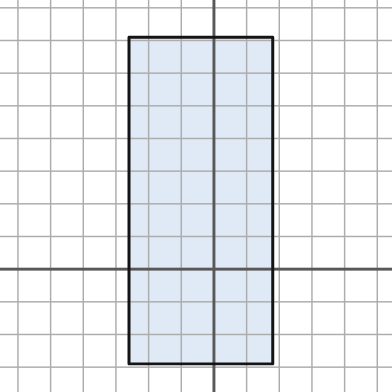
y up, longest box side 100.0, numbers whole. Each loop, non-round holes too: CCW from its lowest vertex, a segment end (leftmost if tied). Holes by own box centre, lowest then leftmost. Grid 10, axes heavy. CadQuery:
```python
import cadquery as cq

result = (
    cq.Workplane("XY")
    .moveTo(-26.0, -29.0)
    .lineTo(18.0, -29.0)
    .lineTo(18.0, 71.0)
    .lineTo(-26.0, 71.0)
    .close()
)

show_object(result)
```